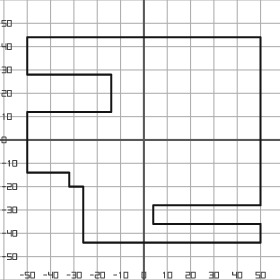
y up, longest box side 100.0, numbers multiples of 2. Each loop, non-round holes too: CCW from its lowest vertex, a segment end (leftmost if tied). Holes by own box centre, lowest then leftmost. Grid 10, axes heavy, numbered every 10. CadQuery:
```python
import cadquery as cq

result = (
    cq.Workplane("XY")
    .moveTo(-26.0, -44.0)
    .lineTo(50.0, -44.0)
    .lineTo(50.0, -36.0)
    .lineTo(4.0, -36.0)
    .lineTo(4.0, -28.0)
    .lineTo(50.0, -28.0)
    .lineTo(50.0, 44.0)
    .lineTo(-50.0, 44.0)
    .lineTo(-50.0, 28.0)
    .lineTo(-14.0, 28.0)
    .lineTo(-14.0, 12.0)
    .lineTo(-50.0, 12.0)
    .lineTo(-50.0, -14.0)
    .lineTo(-32.0, -14.0)
    .lineTo(-32.0, -20.0)
    .lineTo(-26.0, -20.0)
    .close()
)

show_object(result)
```